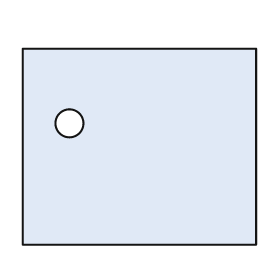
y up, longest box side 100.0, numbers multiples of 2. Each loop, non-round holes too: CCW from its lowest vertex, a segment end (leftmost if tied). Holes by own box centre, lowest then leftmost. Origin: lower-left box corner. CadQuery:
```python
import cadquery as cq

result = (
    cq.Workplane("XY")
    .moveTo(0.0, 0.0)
    .lineTo(100.0, 0.0)
    .lineTo(100.0, 84.0)
    .lineTo(0.0, 84.0)
    .close()
    .moveTo(20.0, 52.0)
    .circle(6.0)
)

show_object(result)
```